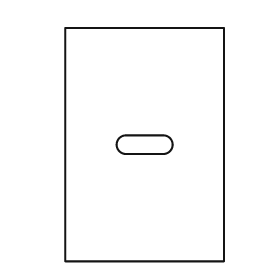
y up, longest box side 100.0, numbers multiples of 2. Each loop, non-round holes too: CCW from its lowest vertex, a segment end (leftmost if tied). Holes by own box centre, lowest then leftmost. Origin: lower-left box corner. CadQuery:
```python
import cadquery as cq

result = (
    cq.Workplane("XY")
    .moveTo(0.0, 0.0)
    .lineTo(68.0, 0.0)
    .lineTo(68.0, 100.0)
    .lineTo(0.0, 100.0)
    .close()
    .moveTo(26.0, 46.0)
    .lineTo(42.0, 46.0)
    .threePointArc((46.0, 50.0), (42.0, 54.0))
    .lineTo(26.0, 54.0)
    .threePointArc((22.0, 50.0), (26.0, 46.0))
    .close()
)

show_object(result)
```